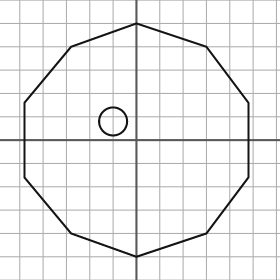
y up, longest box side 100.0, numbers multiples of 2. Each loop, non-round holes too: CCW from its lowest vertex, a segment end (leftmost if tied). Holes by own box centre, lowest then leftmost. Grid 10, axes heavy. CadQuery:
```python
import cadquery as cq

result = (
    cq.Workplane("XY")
    .moveTo(0.0, -50.0)
    .lineTo(30.0, -40.0)
    .lineTo(48.0, -16.0)
    .lineTo(48.0, 16.0)
    .lineTo(30.0, 40.0)
    .lineTo(0.0, 50.0)
    .lineTo(-28.0, 40.0)
    .lineTo(-48.0, 16.0)
    .lineTo(-48.0, -16.0)
    .lineTo(-28.0, -40.0)
    .close()
    .moveTo(-10.0, 8.0)
    .circle(6.0)
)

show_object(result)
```